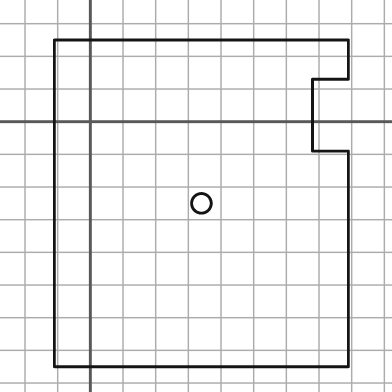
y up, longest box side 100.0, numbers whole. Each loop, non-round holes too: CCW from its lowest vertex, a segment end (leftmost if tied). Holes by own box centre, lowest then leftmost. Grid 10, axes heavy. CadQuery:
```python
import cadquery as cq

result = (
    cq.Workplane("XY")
    .moveTo(-11.0, -75.0)
    .lineTo(79.0, -75.0)
    .lineTo(79.0, -9.0)
    .lineTo(68.0, -9.0)
    .lineTo(68.0, 13.0)
    .lineTo(79.0, 13.0)
    .lineTo(79.0, 25.0)
    .lineTo(-11.0, 25.0)
    .close()
    .moveTo(34.0, -25.0)
    .circle(3.0)
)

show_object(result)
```